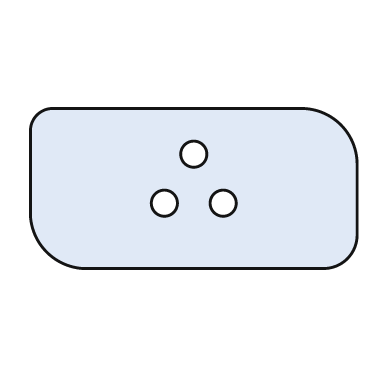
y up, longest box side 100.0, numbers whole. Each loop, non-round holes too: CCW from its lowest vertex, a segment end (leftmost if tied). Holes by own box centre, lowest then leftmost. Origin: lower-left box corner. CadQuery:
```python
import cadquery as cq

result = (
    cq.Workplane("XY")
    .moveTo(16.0, 0.0)
    .lineTo(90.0, 0.0)
    .threePointArc((97.0, 3.0), (100.0, 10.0))
    .lineTo(100.0, 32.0)
    .threePointArc((95.0, 44.0), (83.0, 49.0))
    .lineTo(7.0, 49.0)
    .threePointArc((2.0, 47.0), (0.0, 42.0))
    .lineTo(0.0, 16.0)
    .threePointArc((5.0, 5.0), (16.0, 0.0))
    .close()
    .moveTo(41.0, 20.0)
    .circle(4.0)
    .moveTo(59.0, 20.0)
    .circle(4.0)
    .moveTo(50.0, 35.0)
    .circle(4.0)
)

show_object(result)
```